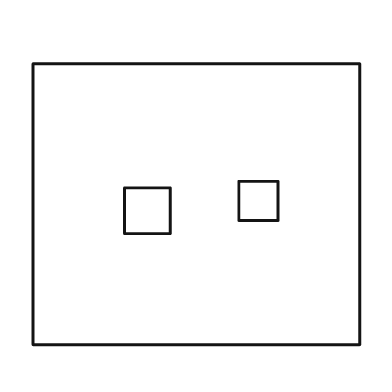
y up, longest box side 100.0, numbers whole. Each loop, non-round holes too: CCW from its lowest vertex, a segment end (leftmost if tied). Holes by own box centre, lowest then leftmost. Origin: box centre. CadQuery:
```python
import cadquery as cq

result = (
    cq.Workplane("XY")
    .moveTo(-50.0, -43.0)
    .lineTo(50.0, -43.0)
    .lineTo(50.0, 43.0)
    .lineTo(-50.0, 43.0)
    .close()
    .moveTo(-22.0, -9.0)
    .lineTo(-8.0, -9.0)
    .lineTo(-8.0, 5.0)
    .lineTo(-22.0, 5.0)
    .close()
    .moveTo(13.0, -5.0)
    .lineTo(25.0, -5.0)
    .lineTo(25.0, 7.0)
    .lineTo(13.0, 7.0)
    .close()
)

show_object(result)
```